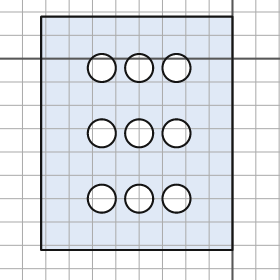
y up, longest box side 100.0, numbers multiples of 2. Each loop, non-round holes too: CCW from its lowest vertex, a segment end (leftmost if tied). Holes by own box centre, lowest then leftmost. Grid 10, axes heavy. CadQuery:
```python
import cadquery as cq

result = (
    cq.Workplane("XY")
    .moveTo(-82.0, -82.0)
    .lineTo(0.0, -82.0)
    .lineTo(0.0, 18.0)
    .lineTo(-82.0, 18.0)
    .close()
    .moveTo(-56.0, -60.0)
    .circle(6.0)
    .moveTo(-40.0, -60.0)
    .circle(6.0)
    .moveTo(-24.0, -60.0)
    .circle(6.0)
    .moveTo(-56.0, -32.0)
    .circle(6.0)
    .moveTo(-40.0, -32.0)
    .circle(6.0)
    .moveTo(-24.0, -32.0)
    .circle(6.0)
    .moveTo(-56.0, -4.0)
    .circle(6.0)
    .moveTo(-40.0, -4.0)
    .circle(6.0)
    .moveTo(-24.0, -4.0)
    .circle(6.0)
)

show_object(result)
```